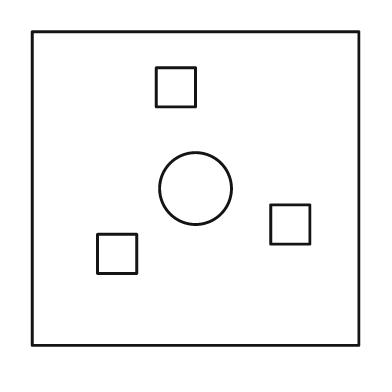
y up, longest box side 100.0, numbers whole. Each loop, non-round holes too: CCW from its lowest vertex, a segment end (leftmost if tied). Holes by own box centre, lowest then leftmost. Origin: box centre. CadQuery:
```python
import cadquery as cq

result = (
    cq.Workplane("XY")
    .moveTo(-50.0, -48.0)
    .lineTo(50.0, -48.0)
    .lineTo(50.0, 48.0)
    .lineTo(-50.0, 48.0)
    .close()
    .moveTo(-30.0, -26.0)
    .lineTo(-18.0, -26.0)
    .lineTo(-18.0, -14.0)
    .lineTo(-30.0, -14.0)
    .close()
    .moveTo(23.0, -17.0)
    .lineTo(35.0, -17.0)
    .lineTo(35.0, -5.0)
    .lineTo(23.0, -5.0)
    .close()
    .moveTo(0.0, 0.0)
    .circle(11.0)
    .moveTo(-12.0, 25.0)
    .lineTo(0.0, 25.0)
    .lineTo(0.0, 37.0)
    .lineTo(-12.0, 37.0)
    .close()
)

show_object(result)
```